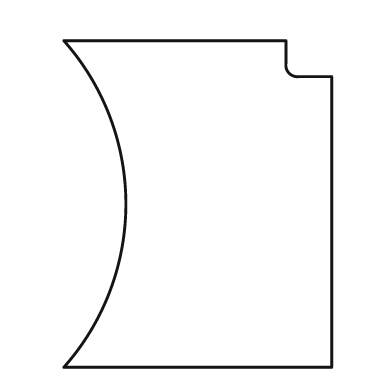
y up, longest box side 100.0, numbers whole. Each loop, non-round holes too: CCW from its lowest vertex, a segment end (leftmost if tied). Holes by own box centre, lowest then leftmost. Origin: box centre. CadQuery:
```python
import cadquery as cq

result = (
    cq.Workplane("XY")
    .moveTo(-41.0, -50.0)
    .lineTo(41.0, -50.0)
    .lineTo(41.0, 39.0)
    .lineTo(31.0, 39.0)
    .threePointArc((28.0, 40.0), (27.0, 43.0))
    .lineTo(27.0, 50.0)
    .lineTo(-41.0, 50.0)
    .threePointArc((-22.0, 0.0), (-41.0, -50.0))
    .close()
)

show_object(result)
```